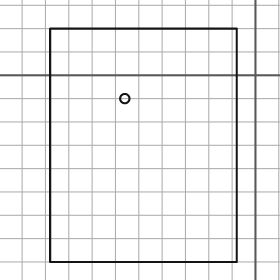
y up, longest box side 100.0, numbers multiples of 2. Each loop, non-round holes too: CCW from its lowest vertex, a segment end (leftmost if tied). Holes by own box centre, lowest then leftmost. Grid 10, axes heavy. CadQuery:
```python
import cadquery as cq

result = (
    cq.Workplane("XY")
    .moveTo(-88.0, -80.0)
    .lineTo(-8.0, -80.0)
    .lineTo(-8.0, 20.0)
    .lineTo(-88.0, 20.0)
    .close()
    .moveTo(-56.0, -10.0)
    .circle(2.0)
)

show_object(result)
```